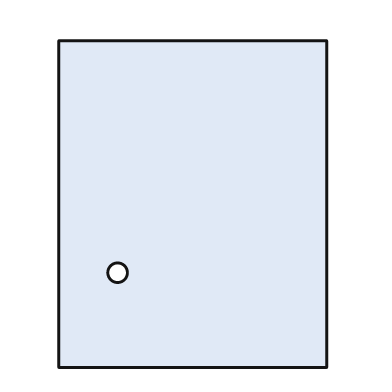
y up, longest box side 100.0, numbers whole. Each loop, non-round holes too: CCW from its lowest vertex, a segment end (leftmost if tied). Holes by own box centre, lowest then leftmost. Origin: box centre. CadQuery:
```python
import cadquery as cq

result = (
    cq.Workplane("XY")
    .moveTo(-41.0, -50.0)
    .lineTo(41.0, -50.0)
    .lineTo(41.0, 50.0)
    .lineTo(-41.0, 50.0)
    .close()
    .moveTo(-23.0, -21.0)
    .circle(3.0)
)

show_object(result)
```